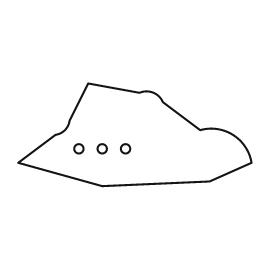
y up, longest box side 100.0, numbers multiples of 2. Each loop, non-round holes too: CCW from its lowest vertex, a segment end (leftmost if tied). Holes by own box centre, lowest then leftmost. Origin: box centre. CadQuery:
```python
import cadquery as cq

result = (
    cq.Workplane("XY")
    .moveTo(-14.0, -22.0)
    .lineTo(32.0, -20.0)
    .lineTo(50.0, -12.0)
    .threePointArc((42.0, 0.0), (28.0, 2.0))
    .lineTo(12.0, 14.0)
    .threePointArc((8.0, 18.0), (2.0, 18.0))
    .lineTo(-20.0, 22.0)
    .lineTo(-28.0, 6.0)
    .threePointArc((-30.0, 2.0), (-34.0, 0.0))
    .lineTo(-50.0, -12.0)
    .close()
    .moveTo(-24.0, -6.0)
    .circle(2.0)
    .moveTo(-14.0, -6.0)
    .circle(2.0)
    .moveTo(-4.0, -6.0)
    .circle(2.0)
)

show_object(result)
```